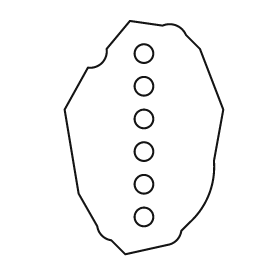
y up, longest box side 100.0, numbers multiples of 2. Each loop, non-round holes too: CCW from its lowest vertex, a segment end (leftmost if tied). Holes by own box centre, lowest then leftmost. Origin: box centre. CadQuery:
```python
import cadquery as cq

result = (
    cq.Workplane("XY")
    .moveTo(-8.0, -50.0)
    .lineTo(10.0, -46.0)
    .threePointArc((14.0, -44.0), (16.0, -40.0))
    .lineTo(20.0, -36.0)
    .threePointArc((28.0, -24.0), (30.0, -10.0))
    .lineTo(34.0, 12.0)
    .lineTo(24.0, 38.0)
    .lineTo(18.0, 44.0)
    .threePointArc((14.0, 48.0), (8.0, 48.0))
    .lineTo(-6.0, 50.0)
    .lineTo(-16.0, 38.0)
    .threePointArc((-18.0, 32.0), (-24.0, 30.0))
    .lineTo(-34.0, 12.0)
    .lineTo(-28.0, -24.0)
    .lineTo(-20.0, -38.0)
    .threePointArc((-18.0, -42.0), (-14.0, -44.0))
    .close()
    .moveTo(0.0, -34.0)
    .circle(4.0)
    .moveTo(0.0, -20.0)
    .circle(4.0)
    .moveTo(0.0, -6.0)
    .circle(4.0)
    .moveTo(0.0, 8.0)
    .circle(4.0)
    .moveTo(0.0, 22.0)
    .circle(4.0)
    .moveTo(0.0, 36.0)
    .circle(4.0)
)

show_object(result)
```